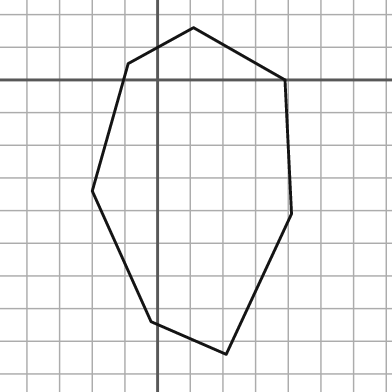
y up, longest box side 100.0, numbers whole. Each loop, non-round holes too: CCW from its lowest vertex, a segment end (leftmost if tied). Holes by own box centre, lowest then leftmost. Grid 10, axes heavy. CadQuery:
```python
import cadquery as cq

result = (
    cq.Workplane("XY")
    .moveTo(21.0, -84.0)
    .lineTo(41.0, -41.0)
    .lineTo(39.0, 0.0)
    .lineTo(11.0, 16.0)
    .lineTo(-9.0, 5.0)
    .lineTo(-20.0, -34.0)
    .lineTo(-2.0, -74.0)
    .close()
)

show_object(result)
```